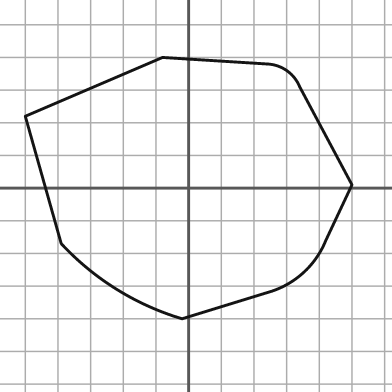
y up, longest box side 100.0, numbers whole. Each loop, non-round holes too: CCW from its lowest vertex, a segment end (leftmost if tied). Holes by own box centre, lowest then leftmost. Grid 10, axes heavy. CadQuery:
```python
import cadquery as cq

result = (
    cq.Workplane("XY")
    .moveTo(-2.0, -40.0)
    .lineTo(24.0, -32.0)
    .threePointArc((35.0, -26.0), (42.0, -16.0))
    .lineTo(50.0, 1.0)
    .lineTo(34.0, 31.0)
    .threePointArc((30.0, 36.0), (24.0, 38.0))
    .lineTo(-8.0, 40.0)
    .lineTo(-50.0, 22.0)
    .lineTo(-39.0, -17.0)
    .threePointArc((-22.0, -31.0), (-2.0, -40.0))
    .close()
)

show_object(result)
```